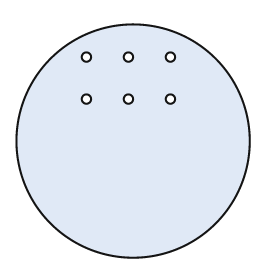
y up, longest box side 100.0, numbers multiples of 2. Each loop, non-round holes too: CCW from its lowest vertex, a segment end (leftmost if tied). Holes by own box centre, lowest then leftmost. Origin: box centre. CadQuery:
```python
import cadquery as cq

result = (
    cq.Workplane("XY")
    .moveTo(0.0, 0.0)
    .circle(50.0)
    .moveTo(-20.0, 18.0)
    .circle(2.0)
    .moveTo(-2.0, 18.0)
    .circle(2.0)
    .moveTo(16.0, 18.0)
    .circle(2.0)
    .moveTo(-20.0, 36.0)
    .circle(2.0)
    .moveTo(-2.0, 36.0)
    .circle(2.0)
    .moveTo(16.0, 36.0)
    .circle(2.0)
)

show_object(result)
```